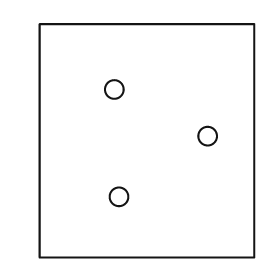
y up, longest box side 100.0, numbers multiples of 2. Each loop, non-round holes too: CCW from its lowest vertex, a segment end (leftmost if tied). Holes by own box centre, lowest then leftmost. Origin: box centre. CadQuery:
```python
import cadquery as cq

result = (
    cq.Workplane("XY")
    .moveTo(-46.0, -50.0)
    .lineTo(46.0, -50.0)
    .lineTo(46.0, 50.0)
    .lineTo(-46.0, 50.0)
    .close()
    .moveTo(-12.0, -24.0)
    .circle(4.0)
    .moveTo(26.0, 2.0)
    .circle(4.0)
    .moveTo(-14.0, 22.0)
    .circle(4.0)
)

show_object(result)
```